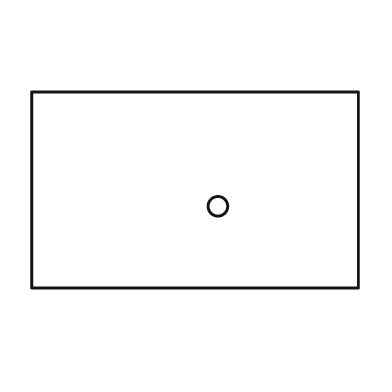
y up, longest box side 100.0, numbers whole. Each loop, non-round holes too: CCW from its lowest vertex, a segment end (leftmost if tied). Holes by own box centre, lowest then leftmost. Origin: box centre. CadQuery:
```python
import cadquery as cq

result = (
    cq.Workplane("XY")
    .moveTo(-50.0, -30.0)
    .lineTo(50.0, -30.0)
    .lineTo(50.0, 30.0)
    .lineTo(-50.0, 30.0)
    .close()
    .moveTo(7.0, -5.0)
    .circle(3.0)
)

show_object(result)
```